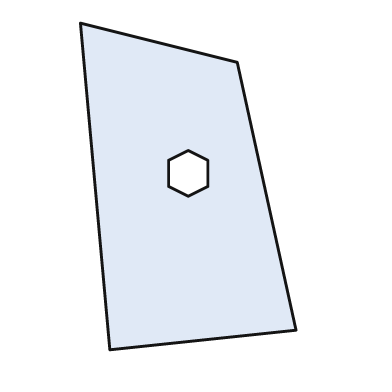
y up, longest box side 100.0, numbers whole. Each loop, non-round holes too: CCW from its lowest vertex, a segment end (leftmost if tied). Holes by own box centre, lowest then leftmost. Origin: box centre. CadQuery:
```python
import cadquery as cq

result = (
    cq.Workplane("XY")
    .moveTo(-24.0, -50.0)
    .lineTo(33.0, -44.0)
    .lineTo(15.0, 38.0)
    .lineTo(-33.0, 50.0)
    .close()
    .moveTo(0.0, -3.0)
    .lineTo(6.0, 0.0)
    .lineTo(6.0, 8.0)
    .lineTo(0.0, 11.0)
    .lineTo(-6.0, 8.0)
    .lineTo(-6.0, 0.0)
    .close()
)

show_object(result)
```